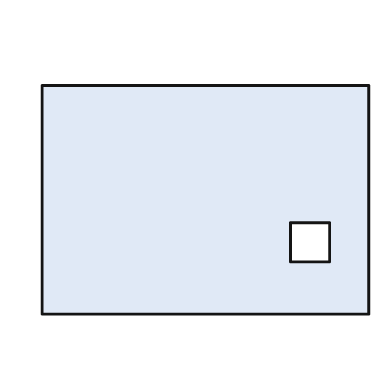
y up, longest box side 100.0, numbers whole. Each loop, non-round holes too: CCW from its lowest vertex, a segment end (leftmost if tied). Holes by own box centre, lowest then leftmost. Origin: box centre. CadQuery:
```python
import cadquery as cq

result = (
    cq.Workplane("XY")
    .moveTo(-50.0, -35.0)
    .lineTo(50.0, -35.0)
    .lineTo(50.0, 35.0)
    .lineTo(-50.0, 35.0)
    .close()
    .moveTo(26.0, -19.0)
    .lineTo(38.0, -19.0)
    .lineTo(38.0, -7.0)
    .lineTo(26.0, -7.0)
    .close()
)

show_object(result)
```